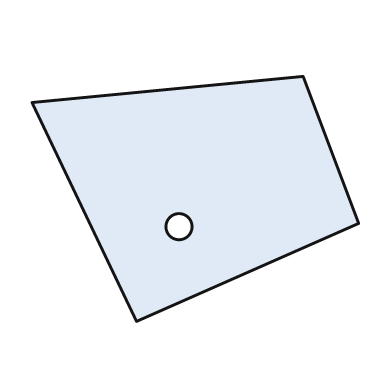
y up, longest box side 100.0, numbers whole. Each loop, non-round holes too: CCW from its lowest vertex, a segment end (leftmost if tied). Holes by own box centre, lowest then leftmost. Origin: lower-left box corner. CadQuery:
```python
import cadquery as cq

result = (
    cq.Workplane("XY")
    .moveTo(32.0, 0.0)
    .lineTo(100.0, 30.0)
    .lineTo(83.0, 75.0)
    .lineTo(0.0, 67.0)
    .close()
    .moveTo(45.0, 29.0)
    .circle(4.0)
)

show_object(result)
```